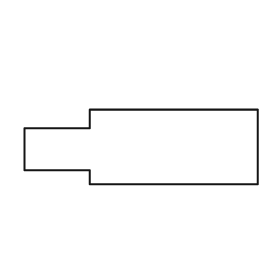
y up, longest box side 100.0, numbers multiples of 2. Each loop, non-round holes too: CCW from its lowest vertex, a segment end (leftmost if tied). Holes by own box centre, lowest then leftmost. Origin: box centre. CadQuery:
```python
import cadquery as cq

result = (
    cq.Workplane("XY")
    .moveTo(-22.0, -16.0)
    .lineTo(50.0, -16.0)
    .lineTo(50.0, 16.0)
    .lineTo(-22.0, 16.0)
    .lineTo(-22.0, 8.0)
    .lineTo(-50.0, 8.0)
    .lineTo(-50.0, -10.0)
    .lineTo(-22.0, -10.0)
    .close()
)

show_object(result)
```